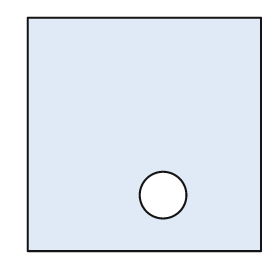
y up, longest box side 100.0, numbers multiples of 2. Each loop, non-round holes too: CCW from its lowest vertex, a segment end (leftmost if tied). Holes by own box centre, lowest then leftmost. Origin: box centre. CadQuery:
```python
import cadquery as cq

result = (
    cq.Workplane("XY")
    .moveTo(-50.0, -50.0)
    .lineTo(50.0, -50.0)
    .lineTo(50.0, 50.0)
    .lineTo(-50.0, 50.0)
    .close()
    .moveTo(8.0, -26.0)
    .circle(10.0)
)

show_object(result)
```